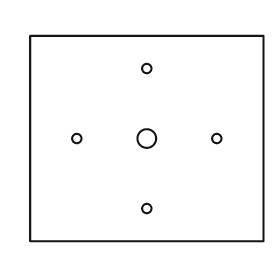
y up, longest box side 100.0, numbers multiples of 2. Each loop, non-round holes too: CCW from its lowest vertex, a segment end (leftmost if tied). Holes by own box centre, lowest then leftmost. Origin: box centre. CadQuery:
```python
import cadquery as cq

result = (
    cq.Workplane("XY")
    .moveTo(-50.0, -44.0)
    .lineTo(50.0, -44.0)
    .lineTo(50.0, 44.0)
    .lineTo(-50.0, 44.0)
    .close()
    .moveTo(0.0, -30.0)
    .circle(2.0)
    .moveTo(-30.0, 0.0)
    .circle(2.0)
    .moveTo(0.0, 0.0)
    .circle(4.0)
    .moveTo(30.0, 0.0)
    .circle(2.0)
    .moveTo(0.0, 30.0)
    .circle(2.0)
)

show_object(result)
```